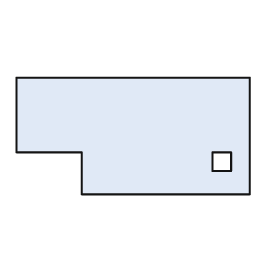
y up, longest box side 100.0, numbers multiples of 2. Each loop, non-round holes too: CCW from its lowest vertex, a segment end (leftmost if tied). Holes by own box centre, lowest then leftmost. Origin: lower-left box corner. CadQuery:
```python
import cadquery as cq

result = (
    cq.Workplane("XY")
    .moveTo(28.0, 0.0)
    .lineTo(100.0, 0.0)
    .lineTo(100.0, 50.0)
    .lineTo(0.0, 50.0)
    .lineTo(0.0, 18.0)
    .lineTo(28.0, 18.0)
    .close()
    .moveTo(84.0, 10.0)
    .lineTo(92.0, 10.0)
    .lineTo(92.0, 18.0)
    .lineTo(84.0, 18.0)
    .close()
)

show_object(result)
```